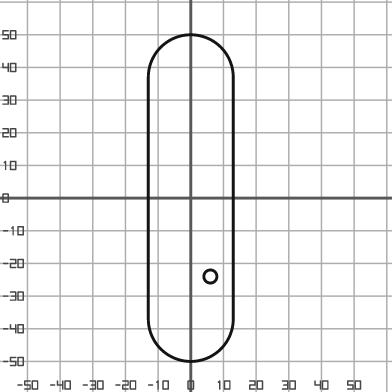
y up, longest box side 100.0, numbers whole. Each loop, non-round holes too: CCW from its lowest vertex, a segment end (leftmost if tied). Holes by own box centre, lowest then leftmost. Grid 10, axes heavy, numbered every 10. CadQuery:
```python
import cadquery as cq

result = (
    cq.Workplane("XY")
    .moveTo(-13.0, -37.0)
    .threePointArc((0.0, -50.0), (13.0, -37.0))
    .lineTo(13.0, 37.0)
    .threePointArc((0.0, 50.0), (-13.0, 37.0))
    .close()
    .moveTo(6.0, -24.0)
    .circle(2.0)
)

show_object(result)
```